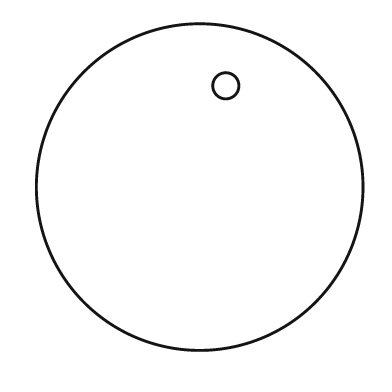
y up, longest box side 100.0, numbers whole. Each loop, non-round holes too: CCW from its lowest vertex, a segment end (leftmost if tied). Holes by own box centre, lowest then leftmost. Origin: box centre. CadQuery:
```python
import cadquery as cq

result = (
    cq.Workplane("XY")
    .moveTo(0.0, 0.0)
    .circle(50.0)
    .moveTo(8.0, 31.0)
    .circle(4.0)
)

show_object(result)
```